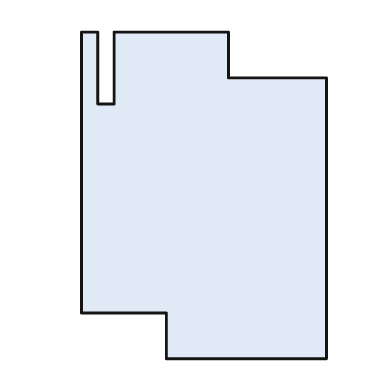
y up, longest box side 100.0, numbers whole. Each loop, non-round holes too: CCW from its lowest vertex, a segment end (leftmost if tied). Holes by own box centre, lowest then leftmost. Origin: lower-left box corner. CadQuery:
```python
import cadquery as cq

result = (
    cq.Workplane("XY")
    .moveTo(26.0, 0.0)
    .lineTo(75.0, 0.0)
    .lineTo(75.0, 86.0)
    .lineTo(45.0, 86.0)
    .lineTo(45.0, 100.0)
    .lineTo(10.0, 100.0)
    .lineTo(10.0, 78.0)
    .lineTo(5.0, 78.0)
    .lineTo(5.0, 100.0)
    .lineTo(0.0, 100.0)
    .lineTo(0.0, 14.0)
    .lineTo(26.0, 14.0)
    .close()
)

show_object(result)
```